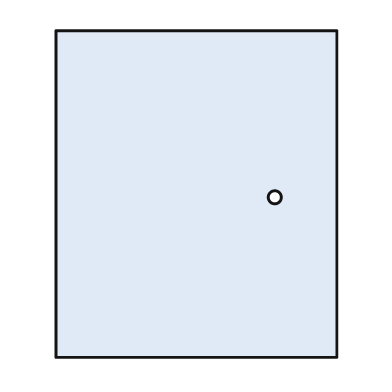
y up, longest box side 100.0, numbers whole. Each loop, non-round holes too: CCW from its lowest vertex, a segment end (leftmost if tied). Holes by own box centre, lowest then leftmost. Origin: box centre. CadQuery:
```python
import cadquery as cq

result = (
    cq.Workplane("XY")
    .moveTo(-43.0, -50.0)
    .lineTo(43.0, -50.0)
    .lineTo(43.0, 50.0)
    .lineTo(-43.0, 50.0)
    .close()
    .moveTo(24.0, -1.0)
    .circle(2.0)
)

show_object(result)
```